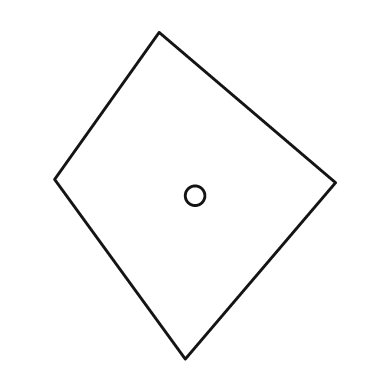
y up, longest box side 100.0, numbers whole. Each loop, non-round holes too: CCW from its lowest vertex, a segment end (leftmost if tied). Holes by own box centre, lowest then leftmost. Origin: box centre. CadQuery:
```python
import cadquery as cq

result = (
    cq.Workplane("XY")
    .moveTo(-3.0, -50.0)
    .lineTo(43.0, 4.0)
    .lineTo(-11.0, 50.0)
    .lineTo(-43.0, 5.0)
    .close()
    .moveTo(0.0, 0.0)
    .circle(3.0)
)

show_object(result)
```